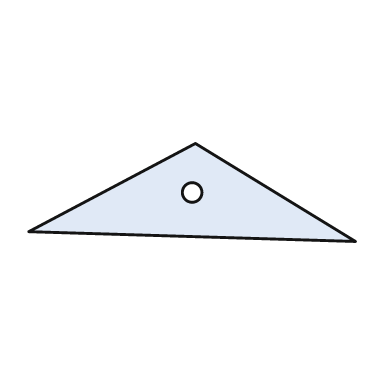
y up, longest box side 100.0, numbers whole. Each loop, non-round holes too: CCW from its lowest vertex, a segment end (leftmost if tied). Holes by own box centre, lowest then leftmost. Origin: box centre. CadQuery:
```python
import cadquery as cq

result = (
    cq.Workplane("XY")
    .moveTo(50.0, -15.0)
    .lineTo(1.0, 15.0)
    .lineTo(-50.0, -12.0)
    .close()
    .moveTo(0.0, 0.0)
    .circle(3.0)
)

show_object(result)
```